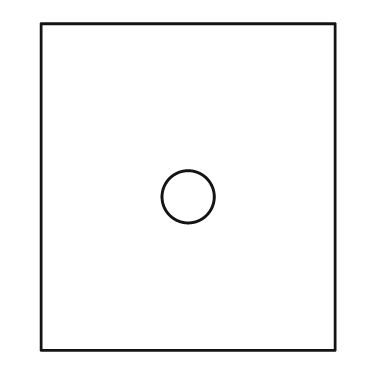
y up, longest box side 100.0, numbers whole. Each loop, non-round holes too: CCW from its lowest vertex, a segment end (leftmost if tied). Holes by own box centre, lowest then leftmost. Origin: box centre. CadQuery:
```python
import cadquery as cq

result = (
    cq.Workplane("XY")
    .moveTo(-45.0, -50.0)
    .lineTo(45.0, -50.0)
    .lineTo(45.0, 50.0)
    .lineTo(-45.0, 50.0)
    .close()
    .moveTo(0.0, -3.0)
    .circle(8.0)
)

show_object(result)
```